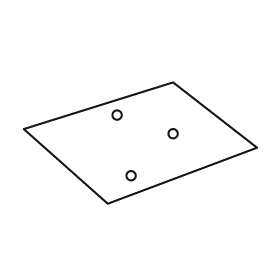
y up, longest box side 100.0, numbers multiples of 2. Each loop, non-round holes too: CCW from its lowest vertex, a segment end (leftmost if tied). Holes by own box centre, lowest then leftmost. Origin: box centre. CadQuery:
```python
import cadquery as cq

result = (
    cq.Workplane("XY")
    .moveTo(-14.0, -26.0)
    .lineTo(50.0, -2.0)
    .lineTo(14.0, 26.0)
    .lineTo(-50.0, 6.0)
    .close()
    .moveTo(-4.0, -14.0)
    .circle(2.0)
    .moveTo(14.0, 4.0)
    .circle(2.0)
    .moveTo(-10.0, 12.0)
    .circle(2.0)
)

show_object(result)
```